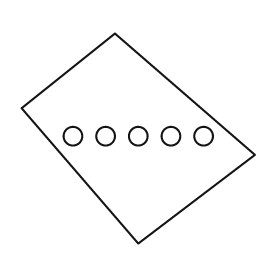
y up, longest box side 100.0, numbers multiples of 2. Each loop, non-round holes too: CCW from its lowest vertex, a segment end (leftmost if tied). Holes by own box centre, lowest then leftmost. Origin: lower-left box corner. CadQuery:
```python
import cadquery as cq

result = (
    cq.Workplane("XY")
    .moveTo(50.0, 0.0)
    .lineTo(100.0, 38.0)
    .lineTo(40.0, 90.0)
    .lineTo(0.0, 58.0)
    .close()
    .moveTo(22.0, 46.0)
    .circle(4.0)
    .moveTo(36.0, 46.0)
    .circle(4.0)
    .moveTo(50.0, 46.0)
    .circle(4.0)
    .moveTo(64.0, 46.0)
    .circle(4.0)
    .moveTo(78.0, 46.0)
    .circle(4.0)
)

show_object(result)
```